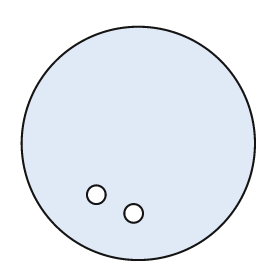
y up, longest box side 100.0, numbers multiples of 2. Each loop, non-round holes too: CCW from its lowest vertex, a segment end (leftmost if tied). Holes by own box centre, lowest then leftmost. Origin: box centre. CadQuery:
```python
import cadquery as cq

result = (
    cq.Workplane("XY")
    .moveTo(0.0, 0.0)
    .circle(50.0)
    .moveTo(-2.0, -30.0)
    .circle(4.0)
    .moveTo(-18.0, -22.0)
    .circle(4.0)
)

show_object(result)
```